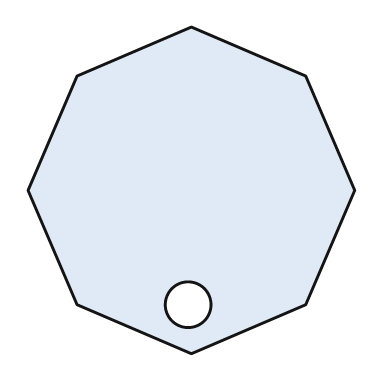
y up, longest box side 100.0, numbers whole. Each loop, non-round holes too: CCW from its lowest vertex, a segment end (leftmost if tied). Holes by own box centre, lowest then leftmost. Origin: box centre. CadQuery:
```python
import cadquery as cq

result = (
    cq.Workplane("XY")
    .moveTo(0.0, -50.0)
    .lineTo(35.0, -35.0)
    .lineTo(50.0, 0.0)
    .lineTo(35.0, 35.0)
    .lineTo(0.0, 50.0)
    .lineTo(-35.0, 35.0)
    .lineTo(-50.0, 0.0)
    .lineTo(-35.0, -35.0)
    .close()
    .moveTo(-1.0, -35.0)
    .circle(7.0)
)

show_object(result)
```